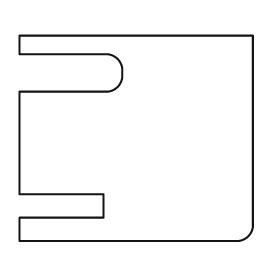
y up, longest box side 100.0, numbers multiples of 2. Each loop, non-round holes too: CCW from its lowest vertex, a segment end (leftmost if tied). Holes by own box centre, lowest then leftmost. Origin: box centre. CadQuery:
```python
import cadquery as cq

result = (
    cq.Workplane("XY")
    .moveTo(-50.0, -44.0)
    .lineTo(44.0, -44.0)
    .threePointArc((48.0, -42.0), (50.0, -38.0))
    .lineTo(50.0, 44.0)
    .lineTo(-50.0, 44.0)
    .lineTo(-50.0, 36.0)
    .lineTo(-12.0, 36.0)
    .threePointArc((-8.0, 34.0), (-6.0, 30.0))
    .lineTo(-6.0, 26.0)
    .threePointArc((-8.0, 22.0), (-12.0, 20.0))
    .lineTo(-50.0, 20.0)
    .lineTo(-50.0, -24.0)
    .lineTo(-14.0, -24.0)
    .lineTo(-14.0, -34.0)
    .lineTo(-50.0, -34.0)
    .close()
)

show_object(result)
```